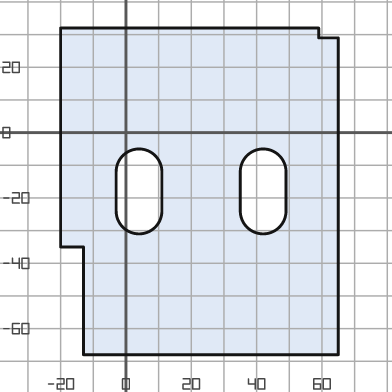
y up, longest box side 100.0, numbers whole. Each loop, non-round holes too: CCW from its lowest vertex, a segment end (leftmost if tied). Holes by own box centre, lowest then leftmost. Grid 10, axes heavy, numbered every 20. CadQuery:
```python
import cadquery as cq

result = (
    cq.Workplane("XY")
    .moveTo(-13.0, -68.0)
    .lineTo(65.0, -68.0)
    .lineTo(65.0, 29.0)
    .lineTo(59.0, 29.0)
    .lineTo(59.0, 32.0)
    .lineTo(-20.0, 32.0)
    .lineTo(-20.0, -35.0)
    .lineTo(-13.0, -35.0)
    .close()
    .moveTo(-3.0, -24.0)
    .threePointArc((4.0, -31.0), (11.0, -24.0))
    .lineTo(11.0, -12.0)
    .threePointArc((4.0, -5.0), (-3.0, -12.0))
    .close()
    .moveTo(35.0, -24.0)
    .threePointArc((42.0, -31.0), (49.0, -24.0))
    .lineTo(49.0, -12.0)
    .threePointArc((42.0, -5.0), (35.0, -12.0))
    .close()
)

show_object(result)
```